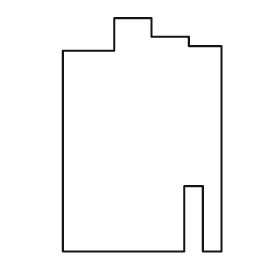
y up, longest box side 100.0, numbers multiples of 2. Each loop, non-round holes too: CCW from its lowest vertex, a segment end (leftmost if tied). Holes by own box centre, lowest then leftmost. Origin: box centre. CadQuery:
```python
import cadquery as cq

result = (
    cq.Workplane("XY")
    .moveTo(-34.0, -50.0)
    .lineTo(18.0, -50.0)
    .lineTo(18.0, -22.0)
    .lineTo(26.0, -22.0)
    .lineTo(26.0, -50.0)
    .lineTo(34.0, -50.0)
    .lineTo(34.0, 38.0)
    .lineTo(20.0, 38.0)
    .lineTo(20.0, 42.0)
    .lineTo(4.0, 42.0)
    .lineTo(4.0, 50.0)
    .lineTo(-12.0, 50.0)
    .lineTo(-12.0, 36.0)
    .lineTo(-34.0, 36.0)
    .close()
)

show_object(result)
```